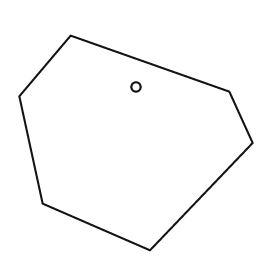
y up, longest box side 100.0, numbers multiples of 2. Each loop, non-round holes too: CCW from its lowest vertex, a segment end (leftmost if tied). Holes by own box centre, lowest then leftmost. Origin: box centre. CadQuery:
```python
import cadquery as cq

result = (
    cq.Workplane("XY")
    .moveTo(6.0, -46.0)
    .lineTo(50.0, 0.0)
    .lineTo(40.0, 22.0)
    .lineTo(-28.0, 46.0)
    .lineTo(-50.0, 20.0)
    .lineTo(-40.0, -26.0)
    .close()
    .moveTo(0.0, 24.0)
    .circle(2.0)
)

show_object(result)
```